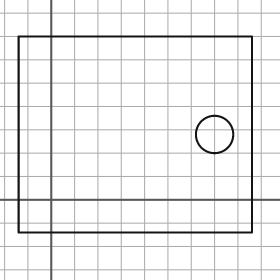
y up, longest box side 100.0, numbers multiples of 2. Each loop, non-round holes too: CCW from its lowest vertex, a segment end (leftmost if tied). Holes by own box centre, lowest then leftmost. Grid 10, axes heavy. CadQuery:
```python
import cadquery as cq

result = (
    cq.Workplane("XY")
    .moveTo(-14.0, -14.0)
    .lineTo(86.0, -14.0)
    .lineTo(86.0, 70.0)
    .lineTo(-14.0, 70.0)
    .close()
    .moveTo(70.0, 28.0)
    .circle(8.0)
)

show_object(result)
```